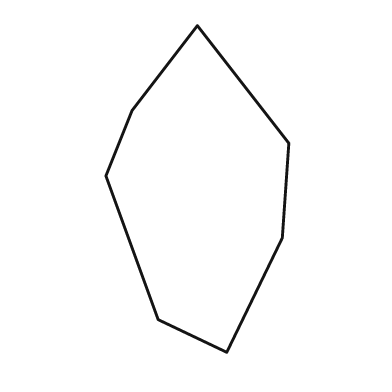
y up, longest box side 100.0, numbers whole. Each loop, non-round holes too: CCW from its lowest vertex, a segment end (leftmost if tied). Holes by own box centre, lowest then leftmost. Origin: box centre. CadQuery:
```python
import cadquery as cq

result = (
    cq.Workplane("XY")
    .moveTo(9.0, -50.0)
    .lineTo(26.0, -15.0)
    .lineTo(28.0, 14.0)
    .lineTo(0.0, 50.0)
    .lineTo(-20.0, 24.0)
    .lineTo(-28.0, 4.0)
    .lineTo(-12.0, -40.0)
    .close()
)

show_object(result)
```